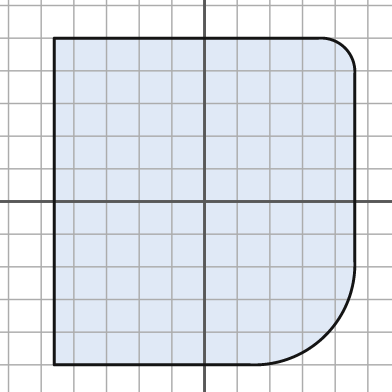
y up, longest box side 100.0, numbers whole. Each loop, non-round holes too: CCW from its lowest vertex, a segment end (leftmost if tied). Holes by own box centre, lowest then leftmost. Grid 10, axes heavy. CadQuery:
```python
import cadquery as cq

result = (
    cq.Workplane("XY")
    .moveTo(-46.0, -50.0)
    .lineTo(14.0, -50.0)
    .threePointArc((37.0, -41.0), (46.0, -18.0))
    .lineTo(46.0, 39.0)
    .threePointArc((43.0, 47.0), (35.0, 50.0))
    .lineTo(-46.0, 50.0)
    .close()
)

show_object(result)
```